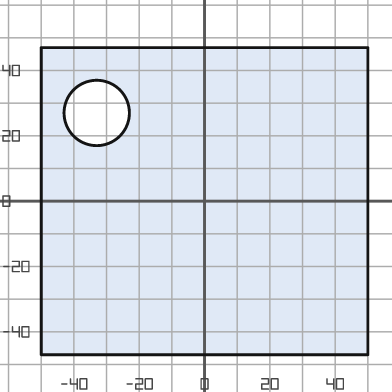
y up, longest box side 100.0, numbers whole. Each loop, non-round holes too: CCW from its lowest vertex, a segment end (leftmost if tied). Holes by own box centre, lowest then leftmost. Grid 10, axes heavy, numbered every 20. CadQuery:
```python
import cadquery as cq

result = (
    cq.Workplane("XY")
    .moveTo(-50.0, -47.0)
    .lineTo(50.0, -47.0)
    .lineTo(50.0, 47.0)
    .lineTo(-50.0, 47.0)
    .close()
    .moveTo(-33.0, 27.0)
    .circle(10.0)
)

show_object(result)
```